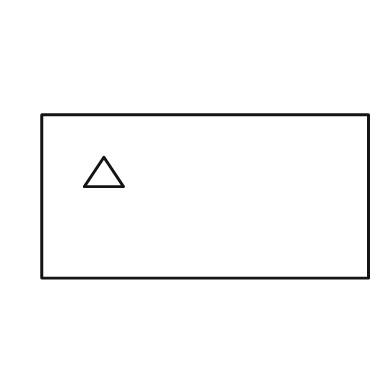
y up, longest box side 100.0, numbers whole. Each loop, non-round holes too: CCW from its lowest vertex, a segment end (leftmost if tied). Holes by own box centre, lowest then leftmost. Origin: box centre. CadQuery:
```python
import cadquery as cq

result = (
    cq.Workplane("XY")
    .moveTo(-50.0, -25.0)
    .lineTo(50.0, -25.0)
    .lineTo(50.0, 25.0)
    .lineTo(-50.0, 25.0)
    .close()
    .moveTo(-37.0, 3.0)
    .lineTo(-25.0, 3.0)
    .lineTo(-31.0, 12.0)
    .close()
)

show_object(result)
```